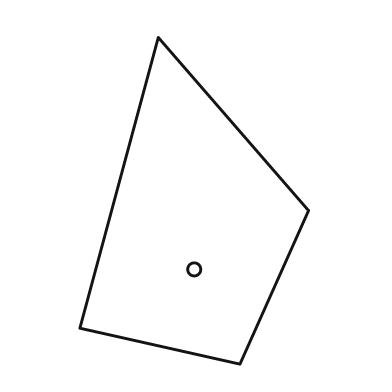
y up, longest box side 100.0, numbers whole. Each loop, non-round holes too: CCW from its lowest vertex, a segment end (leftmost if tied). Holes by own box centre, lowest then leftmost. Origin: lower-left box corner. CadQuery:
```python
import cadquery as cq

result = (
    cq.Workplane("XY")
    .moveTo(49.0, 0.0)
    .lineTo(70.0, 47.0)
    .lineTo(24.0, 100.0)
    .lineTo(0.0, 11.0)
    .close()
    .moveTo(35.0, 29.0)
    .circle(2.0)
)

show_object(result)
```